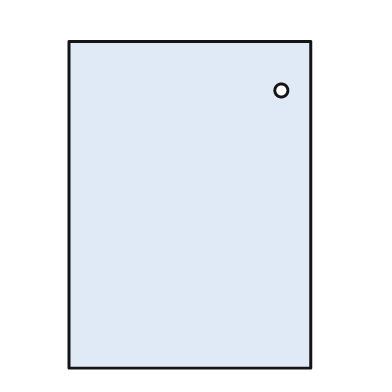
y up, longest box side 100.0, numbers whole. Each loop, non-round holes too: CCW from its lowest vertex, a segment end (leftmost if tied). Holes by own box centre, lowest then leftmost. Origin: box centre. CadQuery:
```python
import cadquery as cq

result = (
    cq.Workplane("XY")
    .moveTo(-37.0, -50.0)
    .lineTo(37.0, -50.0)
    .lineTo(37.0, 50.0)
    .lineTo(-37.0, 50.0)
    .close()
    .moveTo(28.0, 35.0)
    .circle(2.0)
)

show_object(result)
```